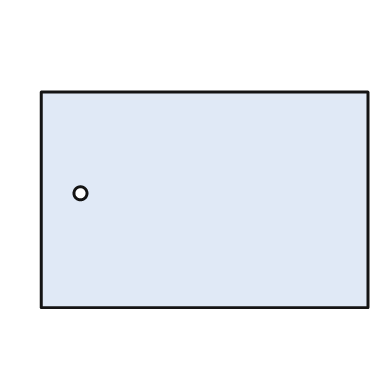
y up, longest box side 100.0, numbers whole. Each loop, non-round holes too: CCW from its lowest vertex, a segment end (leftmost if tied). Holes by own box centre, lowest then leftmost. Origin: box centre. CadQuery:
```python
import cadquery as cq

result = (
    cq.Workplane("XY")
    .moveTo(-50.0, -33.0)
    .lineTo(50.0, -33.0)
    .lineTo(50.0, 33.0)
    .lineTo(-50.0, 33.0)
    .close()
    .moveTo(-38.0, 2.0)
    .circle(2.0)
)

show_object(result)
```